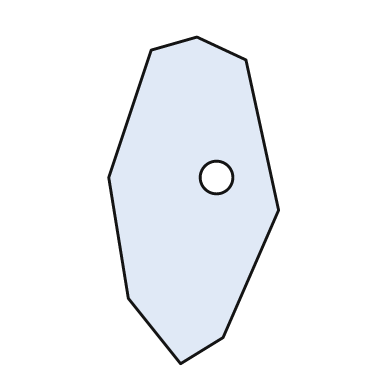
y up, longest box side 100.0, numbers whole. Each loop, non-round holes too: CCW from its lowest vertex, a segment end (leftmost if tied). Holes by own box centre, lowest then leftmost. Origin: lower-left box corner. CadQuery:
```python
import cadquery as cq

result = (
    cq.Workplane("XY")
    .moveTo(22.0, 0.0)
    .lineTo(35.0, 8.0)
    .lineTo(52.0, 47.0)
    .lineTo(42.0, 93.0)
    .lineTo(27.0, 100.0)
    .lineTo(13.0, 96.0)
    .lineTo(0.0, 57.0)
    .lineTo(6.0, 20.0)
    .close()
    .moveTo(33.0, 57.0)
    .circle(5.0)
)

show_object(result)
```